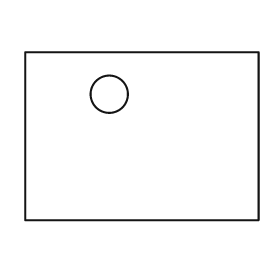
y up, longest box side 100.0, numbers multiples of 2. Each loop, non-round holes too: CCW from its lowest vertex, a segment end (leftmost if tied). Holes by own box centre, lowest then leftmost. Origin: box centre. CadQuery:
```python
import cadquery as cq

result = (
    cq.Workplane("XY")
    .moveTo(-50.0, -36.0)
    .lineTo(50.0, -36.0)
    .lineTo(50.0, 36.0)
    .lineTo(-50.0, 36.0)
    .close()
    .moveTo(-14.0, 18.0)
    .circle(8.0)
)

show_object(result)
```